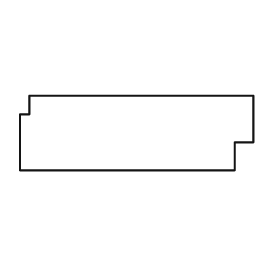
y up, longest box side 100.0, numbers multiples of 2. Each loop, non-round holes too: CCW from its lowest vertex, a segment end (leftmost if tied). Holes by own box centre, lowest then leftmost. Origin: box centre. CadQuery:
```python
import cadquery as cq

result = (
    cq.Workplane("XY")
    .moveTo(-50.0, -16.0)
    .lineTo(42.0, -16.0)
    .lineTo(42.0, -4.0)
    .lineTo(50.0, -4.0)
    .lineTo(50.0, 16.0)
    .lineTo(-46.0, 16.0)
    .lineTo(-46.0, 8.0)
    .lineTo(-50.0, 8.0)
    .close()
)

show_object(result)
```